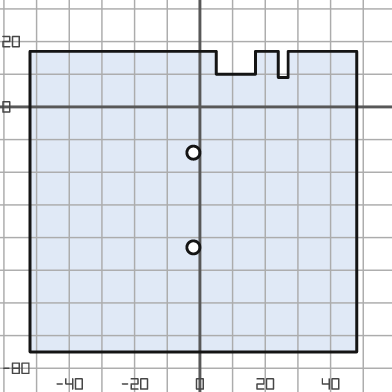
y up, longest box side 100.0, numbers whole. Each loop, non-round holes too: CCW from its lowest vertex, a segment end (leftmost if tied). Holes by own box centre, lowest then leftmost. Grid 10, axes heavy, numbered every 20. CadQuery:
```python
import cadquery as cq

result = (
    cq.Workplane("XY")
    .moveTo(-52.0, -75.0)
    .lineTo(48.0, -75.0)
    .lineTo(48.0, 17.0)
    .lineTo(27.0, 17.0)
    .lineTo(27.0, 9.0)
    .lineTo(24.0, 9.0)
    .lineTo(24.0, 17.0)
    .lineTo(17.0, 17.0)
    .lineTo(17.0, 10.0)
    .lineTo(5.0, 10.0)
    .lineTo(5.0, 17.0)
    .lineTo(-52.0, 17.0)
    .close()
    .moveTo(-2.0, -43.0)
    .circle(2.0)
    .moveTo(-2.0, -14.0)
    .circle(2.0)
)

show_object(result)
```